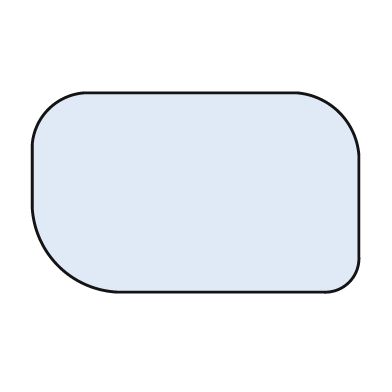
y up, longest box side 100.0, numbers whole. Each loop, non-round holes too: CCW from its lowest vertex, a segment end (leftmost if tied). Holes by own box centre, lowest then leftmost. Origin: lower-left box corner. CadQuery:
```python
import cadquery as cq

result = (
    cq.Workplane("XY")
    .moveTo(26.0, 0.0)
    .lineTo(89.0, 0.0)
    .threePointArc((97.0, 3.0), (100.0, 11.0))
    .lineTo(100.0, 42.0)
    .threePointArc((94.0, 55.0), (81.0, 61.0))
    .lineTo(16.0, 61.0)
    .threePointArc((5.0, 56.0), (0.0, 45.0))
    .lineTo(0.0, 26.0)
    .threePointArc((8.0, 8.0), (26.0, 0.0))
    .close()
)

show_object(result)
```